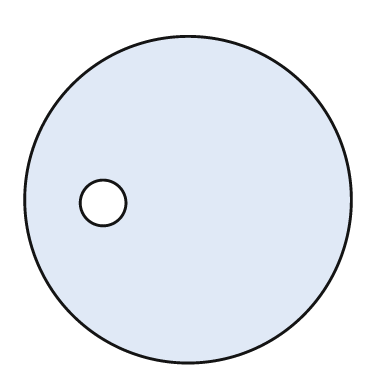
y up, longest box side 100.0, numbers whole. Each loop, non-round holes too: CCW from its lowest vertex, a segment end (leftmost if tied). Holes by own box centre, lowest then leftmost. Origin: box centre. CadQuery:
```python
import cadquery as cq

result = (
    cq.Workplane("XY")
    .moveTo(0.0, 0.0)
    .circle(50.0)
    .moveTo(-26.0, -1.0)
    .circle(7.0)
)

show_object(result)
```